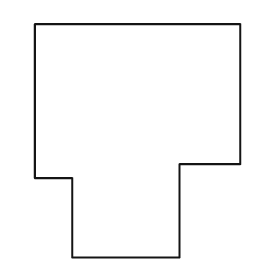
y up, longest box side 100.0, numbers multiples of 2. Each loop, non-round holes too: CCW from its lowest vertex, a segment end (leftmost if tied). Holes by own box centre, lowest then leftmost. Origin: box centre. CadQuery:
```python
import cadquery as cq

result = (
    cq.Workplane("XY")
    .moveTo(-28.0, -50.0)
    .lineTo(18.0, -50.0)
    .lineTo(18.0, -10.0)
    .lineTo(44.0, -10.0)
    .lineTo(44.0, 50.0)
    .lineTo(-44.0, 50.0)
    .lineTo(-44.0, -16.0)
    .lineTo(-28.0, -16.0)
    .close()
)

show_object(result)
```